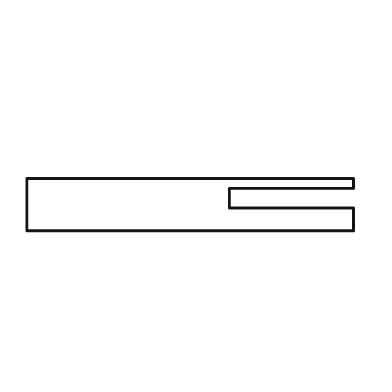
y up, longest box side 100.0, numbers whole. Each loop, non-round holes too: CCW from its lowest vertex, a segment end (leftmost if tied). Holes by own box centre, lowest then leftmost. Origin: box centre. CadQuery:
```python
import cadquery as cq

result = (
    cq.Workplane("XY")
    .moveTo(-50.0, -8.0)
    .lineTo(50.0, -8.0)
    .lineTo(50.0, -1.0)
    .lineTo(12.0, -1.0)
    .lineTo(12.0, 5.0)
    .lineTo(50.0, 5.0)
    .lineTo(50.0, 8.0)
    .lineTo(-50.0, 8.0)
    .close()
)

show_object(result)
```